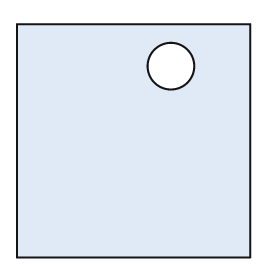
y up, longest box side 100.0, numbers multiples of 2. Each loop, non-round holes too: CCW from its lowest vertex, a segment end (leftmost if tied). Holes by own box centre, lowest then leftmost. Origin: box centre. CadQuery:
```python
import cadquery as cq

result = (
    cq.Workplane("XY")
    .moveTo(-50.0, -50.0)
    .lineTo(50.0, -50.0)
    .lineTo(50.0, 50.0)
    .lineTo(-50.0, 50.0)
    .close()
    .moveTo(16.0, 32.0)
    .circle(10.0)
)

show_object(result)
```